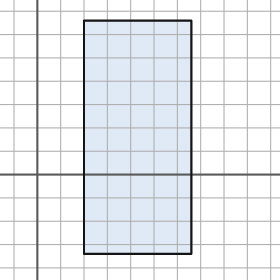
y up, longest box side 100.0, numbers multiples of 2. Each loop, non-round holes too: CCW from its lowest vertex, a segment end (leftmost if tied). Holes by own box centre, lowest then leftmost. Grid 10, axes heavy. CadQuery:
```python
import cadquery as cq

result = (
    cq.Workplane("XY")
    .moveTo(20.0, -34.0)
    .lineTo(66.0, -34.0)
    .lineTo(66.0, 66.0)
    .lineTo(20.0, 66.0)
    .close()
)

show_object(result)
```